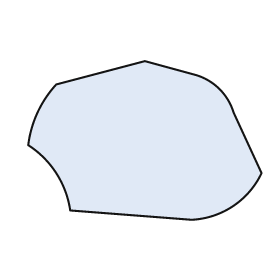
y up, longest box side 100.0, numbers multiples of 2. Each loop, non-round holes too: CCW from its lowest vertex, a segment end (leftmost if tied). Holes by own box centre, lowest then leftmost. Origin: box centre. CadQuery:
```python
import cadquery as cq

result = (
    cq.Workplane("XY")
    .moveTo(20.0, -34.0)
    .threePointArc((38.0, -28.0), (50.0, -14.0))
    .lineTo(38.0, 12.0)
    .threePointArc((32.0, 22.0), (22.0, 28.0))
    .lineTo(0.0, 34.0)
    .lineTo(-38.0, 24.0)
    .threePointArc((-46.0, 12.0), (-50.0, -2.0))
    .threePointArc((-38.0, -14.0), (-32.0, -30.0))
    .close()
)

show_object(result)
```